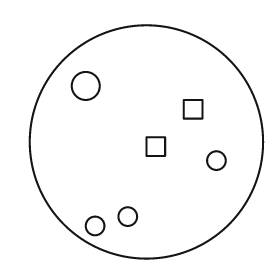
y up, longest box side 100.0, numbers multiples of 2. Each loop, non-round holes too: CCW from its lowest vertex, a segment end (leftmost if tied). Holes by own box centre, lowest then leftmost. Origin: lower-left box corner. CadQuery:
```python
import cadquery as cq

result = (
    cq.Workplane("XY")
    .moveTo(50.0, 50.0)
    .circle(50.0)
    .moveTo(28.0, 14.0)
    .circle(4.0)
    .moveTo(42.0, 18.0)
    .circle(4.0)
    .moveTo(80.0, 42.0)
    .circle(4.0)
    .moveTo(50.0, 44.0)
    .lineTo(58.0, 44.0)
    .lineTo(58.0, 52.0)
    .lineTo(50.0, 52.0)
    .close()
    .moveTo(66.0, 60.0)
    .lineTo(74.0, 60.0)
    .lineTo(74.0, 68.0)
    .lineTo(66.0, 68.0)
    .close()
    .moveTo(24.0, 74.0)
    .circle(6.0)
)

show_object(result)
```